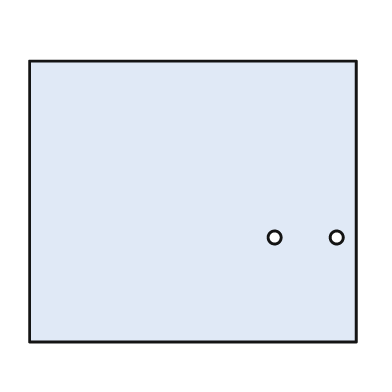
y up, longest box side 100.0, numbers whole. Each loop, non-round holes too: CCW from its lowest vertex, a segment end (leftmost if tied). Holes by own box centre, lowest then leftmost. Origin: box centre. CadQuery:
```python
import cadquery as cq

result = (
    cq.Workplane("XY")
    .moveTo(-50.0, -43.0)
    .lineTo(50.0, -43.0)
    .lineTo(50.0, 43.0)
    .lineTo(-50.0, 43.0)
    .close()
    .moveTo(25.0, -11.0)
    .circle(2.0)
    .moveTo(44.0, -11.0)
    .circle(2.0)
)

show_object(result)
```